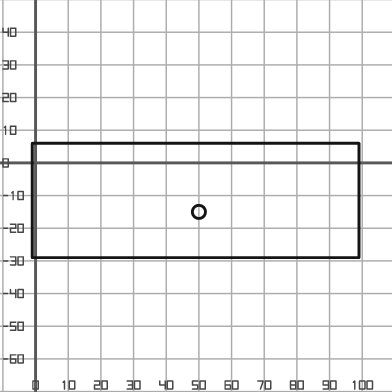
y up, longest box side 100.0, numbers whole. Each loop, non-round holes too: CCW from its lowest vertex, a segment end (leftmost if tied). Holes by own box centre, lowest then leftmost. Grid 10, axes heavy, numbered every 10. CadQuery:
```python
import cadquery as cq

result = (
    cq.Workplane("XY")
    .moveTo(-1.0, -29.0)
    .lineTo(99.0, -29.0)
    .lineTo(99.0, 6.0)
    .lineTo(-1.0, 6.0)
    .close()
    .moveTo(50.0, -15.0)
    .circle(2.0)
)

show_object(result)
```